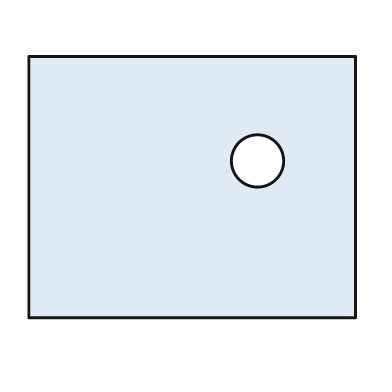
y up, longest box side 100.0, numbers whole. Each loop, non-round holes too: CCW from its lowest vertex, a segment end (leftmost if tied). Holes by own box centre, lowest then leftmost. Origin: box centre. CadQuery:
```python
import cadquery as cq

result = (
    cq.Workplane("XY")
    .moveTo(-50.0, -40.0)
    .lineTo(50.0, -40.0)
    .lineTo(50.0, 40.0)
    .lineTo(-50.0, 40.0)
    .close()
    .moveTo(20.0, 8.0)
    .circle(8.0)
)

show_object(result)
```